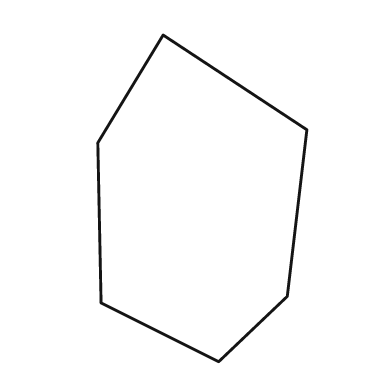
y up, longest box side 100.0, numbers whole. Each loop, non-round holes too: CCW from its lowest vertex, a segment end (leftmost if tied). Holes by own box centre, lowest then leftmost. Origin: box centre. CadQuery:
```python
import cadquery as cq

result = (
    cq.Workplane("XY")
    .moveTo(5.0, -50.0)
    .lineTo(26.0, -30.0)
    .lineTo(32.0, 21.0)
    .lineTo(-12.0, 50.0)
    .lineTo(-32.0, 17.0)
    .lineTo(-31.0, -32.0)
    .close()
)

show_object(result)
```